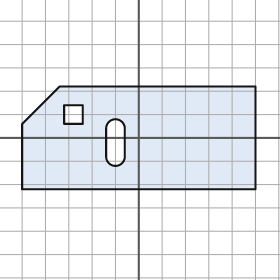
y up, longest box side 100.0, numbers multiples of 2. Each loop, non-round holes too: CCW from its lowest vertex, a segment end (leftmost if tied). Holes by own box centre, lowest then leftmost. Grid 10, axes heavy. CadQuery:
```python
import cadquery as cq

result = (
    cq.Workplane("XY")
    .moveTo(-50.0, -22.0)
    .lineTo(50.0, -22.0)
    .lineTo(50.0, 22.0)
    .lineTo(-34.0, 22.0)
    .lineTo(-50.0, 6.0)
    .close()
    .moveTo(-14.0, -8.0)
    .threePointArc((-10.0, -12.0), (-6.0, -8.0))
    .lineTo(-6.0, 4.0)
    .threePointArc((-10.0, 8.0), (-14.0, 4.0))
    .close()
    .moveTo(-32.0, 6.0)
    .lineTo(-24.0, 6.0)
    .lineTo(-24.0, 14.0)
    .lineTo(-32.0, 14.0)
    .close()
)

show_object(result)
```